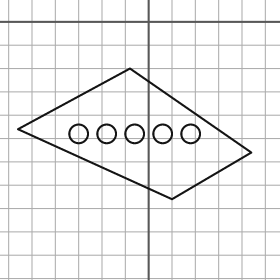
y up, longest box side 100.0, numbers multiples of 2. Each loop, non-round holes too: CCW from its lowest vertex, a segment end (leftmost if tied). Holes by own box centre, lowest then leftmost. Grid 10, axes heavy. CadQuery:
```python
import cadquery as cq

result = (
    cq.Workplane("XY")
    .moveTo(10.0, -76.0)
    .lineTo(44.0, -56.0)
    .lineTo(-8.0, -20.0)
    .lineTo(-56.0, -46.0)
    .close()
    .moveTo(-30.0, -48.0)
    .circle(4.0)
    .moveTo(-18.0, -48.0)
    .circle(4.0)
    .moveTo(-6.0, -48.0)
    .circle(4.0)
    .moveTo(6.0, -48.0)
    .circle(4.0)
    .moveTo(18.0, -48.0)
    .circle(4.0)
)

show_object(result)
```